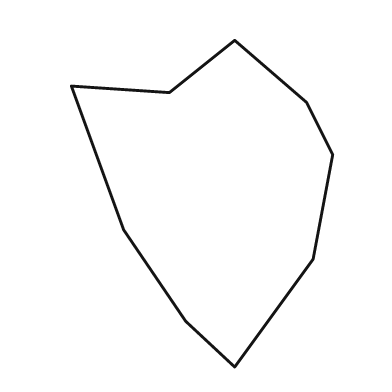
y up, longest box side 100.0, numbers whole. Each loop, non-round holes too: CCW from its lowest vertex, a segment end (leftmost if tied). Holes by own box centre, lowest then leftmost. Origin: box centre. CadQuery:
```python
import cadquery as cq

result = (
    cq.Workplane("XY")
    .moveTo(10.0, -50.0)
    .lineTo(34.0, -17.0)
    .lineTo(40.0, 15.0)
    .lineTo(32.0, 31.0)
    .lineTo(10.0, 50.0)
    .lineTo(-10.0, 34.0)
    .lineTo(-40.0, 36.0)
    .lineTo(-24.0, -8.0)
    .lineTo(-5.0, -36.0)
    .close()
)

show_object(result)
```